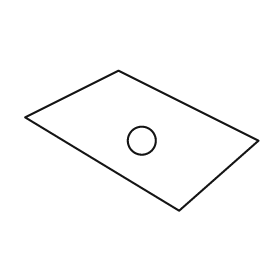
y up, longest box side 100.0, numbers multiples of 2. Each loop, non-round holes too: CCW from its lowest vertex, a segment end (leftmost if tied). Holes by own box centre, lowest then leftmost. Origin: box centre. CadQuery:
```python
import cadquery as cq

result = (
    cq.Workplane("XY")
    .moveTo(16.0, -30.0)
    .lineTo(50.0, 0.0)
    .lineTo(-10.0, 30.0)
    .lineTo(-50.0, 10.0)
    .close()
    .moveTo(0.0, 0.0)
    .circle(6.0)
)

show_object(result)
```